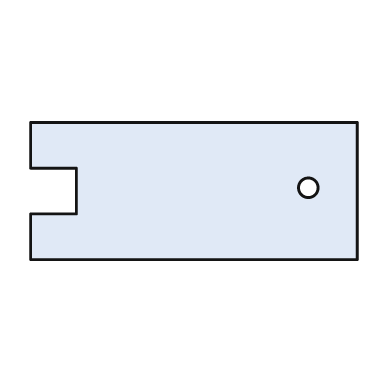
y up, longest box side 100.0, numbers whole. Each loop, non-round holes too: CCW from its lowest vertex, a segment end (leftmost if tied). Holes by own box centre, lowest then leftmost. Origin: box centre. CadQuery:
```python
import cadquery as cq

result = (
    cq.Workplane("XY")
    .moveTo(-50.0, -21.0)
    .lineTo(50.0, -21.0)
    .lineTo(50.0, 21.0)
    .lineTo(-50.0, 21.0)
    .lineTo(-50.0, 7.0)
    .lineTo(-36.0, 7.0)
    .lineTo(-36.0, -7.0)
    .lineTo(-50.0, -7.0)
    .close()
    .moveTo(35.0, 1.0)
    .circle(3.0)
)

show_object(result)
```